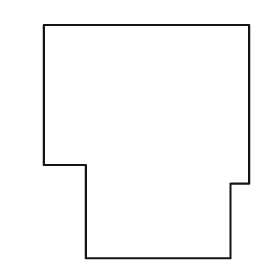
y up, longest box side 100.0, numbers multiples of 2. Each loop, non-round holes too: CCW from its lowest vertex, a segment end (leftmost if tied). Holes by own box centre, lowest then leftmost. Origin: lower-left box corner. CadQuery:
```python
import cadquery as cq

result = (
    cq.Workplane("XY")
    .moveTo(18.0, 0.0)
    .lineTo(80.0, 0.0)
    .lineTo(80.0, 32.0)
    .lineTo(88.0, 32.0)
    .lineTo(88.0, 100.0)
    .lineTo(0.0, 100.0)
    .lineTo(0.0, 40.0)
    .lineTo(18.0, 40.0)
    .close()
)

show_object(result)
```